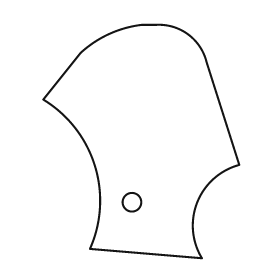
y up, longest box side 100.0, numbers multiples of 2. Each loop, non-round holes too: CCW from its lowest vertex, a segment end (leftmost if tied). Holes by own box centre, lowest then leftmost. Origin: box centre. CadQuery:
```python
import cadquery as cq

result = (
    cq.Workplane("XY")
    .moveTo(26.0, -50.0)
    .threePointArc((24.0, -26.0), (42.0, -10.0))
    .lineTo(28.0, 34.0)
    .threePointArc((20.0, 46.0), (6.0, 50.0))
    .lineTo(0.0, 50.0)
    .threePointArc((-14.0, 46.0), (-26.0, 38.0))
    .lineTo(-42.0, 18.0)
    .threePointArc((-20.0, -10.0), (-22.0, -46.0))
    .close()
    .moveTo(-4.0, -26.0)
    .circle(4.0)
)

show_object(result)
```